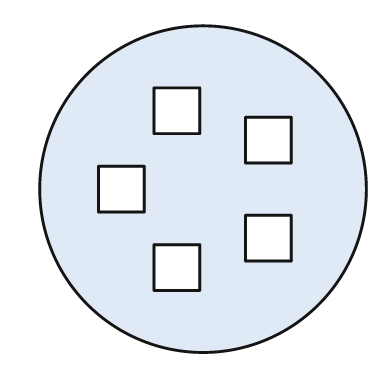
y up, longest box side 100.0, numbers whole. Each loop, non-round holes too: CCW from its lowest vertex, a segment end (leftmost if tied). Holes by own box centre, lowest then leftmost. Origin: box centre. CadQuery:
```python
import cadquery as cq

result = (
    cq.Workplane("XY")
    .moveTo(0.0, 0.0)
    .circle(50.0)
    .moveTo(-15.0, -31.0)
    .lineTo(-1.0, -31.0)
    .lineTo(-1.0, -17.0)
    .lineTo(-15.0, -17.0)
    .close()
    .moveTo(13.0, -22.0)
    .lineTo(27.0, -22.0)
    .lineTo(27.0, -8.0)
    .lineTo(13.0, -8.0)
    .close()
    .moveTo(-32.0, -7.0)
    .lineTo(-18.0, -7.0)
    .lineTo(-18.0, 7.0)
    .lineTo(-32.0, 7.0)
    .close()
    .moveTo(13.0, 8.0)
    .lineTo(27.0, 8.0)
    .lineTo(27.0, 22.0)
    .lineTo(13.0, 22.0)
    .close()
    .moveTo(-15.0, 17.0)
    .lineTo(-1.0, 17.0)
    .lineTo(-1.0, 31.0)
    .lineTo(-15.0, 31.0)
    .close()
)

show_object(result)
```